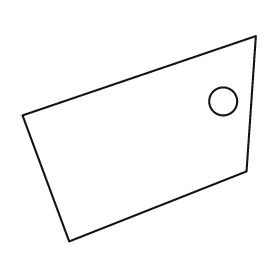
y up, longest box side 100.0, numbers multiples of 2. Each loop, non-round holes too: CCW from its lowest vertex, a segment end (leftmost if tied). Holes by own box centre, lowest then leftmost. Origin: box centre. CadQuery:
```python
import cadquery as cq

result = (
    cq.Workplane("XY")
    .moveTo(-30.0, -44.0)
    .lineTo(46.0, -14.0)
    .lineTo(50.0, 44.0)
    .lineTo(-50.0, 10.0)
    .close()
    .moveTo(36.0, 16.0)
    .circle(6.0)
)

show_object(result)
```